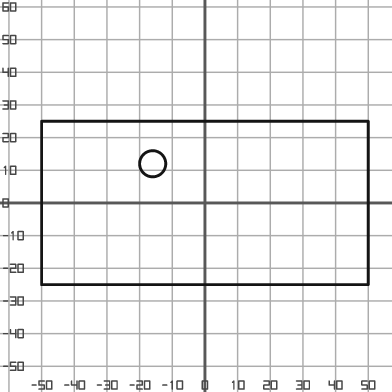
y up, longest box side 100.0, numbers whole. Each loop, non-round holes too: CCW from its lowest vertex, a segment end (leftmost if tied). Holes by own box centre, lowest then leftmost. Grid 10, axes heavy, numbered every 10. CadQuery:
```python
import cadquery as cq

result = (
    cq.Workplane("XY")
    .moveTo(-50.0, -25.0)
    .lineTo(50.0, -25.0)
    .lineTo(50.0, 25.0)
    .lineTo(-50.0, 25.0)
    .close()
    .moveTo(-16.0, 12.0)
    .circle(4.0)
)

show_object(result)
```